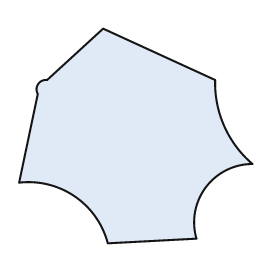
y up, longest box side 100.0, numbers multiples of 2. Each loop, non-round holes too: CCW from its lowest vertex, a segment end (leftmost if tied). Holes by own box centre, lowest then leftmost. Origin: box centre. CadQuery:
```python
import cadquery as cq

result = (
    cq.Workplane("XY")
    .moveTo(-12.0, -46.0)
    .lineTo(26.0, -44.0)
    .threePointArc((30.0, -22.0), (50.0, -12.0))
    .threePointArc((38.0, 4.0), (34.0, 24.0))
    .lineTo(-14.0, 46.0)
    .lineTo(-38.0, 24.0)
    .threePointArc((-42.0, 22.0), (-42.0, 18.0))
    .lineTo(-50.0, -20.0)
    .threePointArc((-26.0, -26.0), (-12.0, -46.0))
    .close()
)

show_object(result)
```